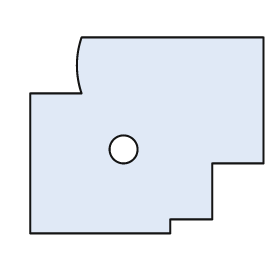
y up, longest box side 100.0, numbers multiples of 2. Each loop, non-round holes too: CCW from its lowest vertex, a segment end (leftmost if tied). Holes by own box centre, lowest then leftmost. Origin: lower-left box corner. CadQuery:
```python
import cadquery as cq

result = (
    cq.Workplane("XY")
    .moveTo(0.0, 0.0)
    .lineTo(60.0, 0.0)
    .lineTo(60.0, 6.0)
    .lineTo(78.0, 6.0)
    .lineTo(78.0, 30.0)
    .lineTo(100.0, 30.0)
    .lineTo(100.0, 84.0)
    .lineTo(22.0, 84.0)
    .threePointArc((20.0, 72.0), (22.0, 60.0))
    .lineTo(0.0, 60.0)
    .close()
    .moveTo(40.0, 36.0)
    .circle(6.0)
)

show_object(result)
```